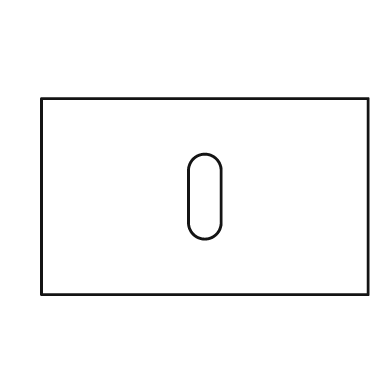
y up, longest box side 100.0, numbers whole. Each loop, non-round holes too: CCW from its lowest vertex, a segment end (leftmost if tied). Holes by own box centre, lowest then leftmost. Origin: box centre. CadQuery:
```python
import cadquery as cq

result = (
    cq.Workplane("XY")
    .moveTo(-50.0, -30.0)
    .lineTo(50.0, -30.0)
    .lineTo(50.0, 30.0)
    .lineTo(-50.0, 30.0)
    .close()
    .moveTo(-5.0, -8.0)
    .threePointArc((0.0, -13.0), (5.0, -8.0))
    .lineTo(5.0, 8.0)
    .threePointArc((0.0, 13.0), (-5.0, 8.0))
    .close()
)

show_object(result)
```